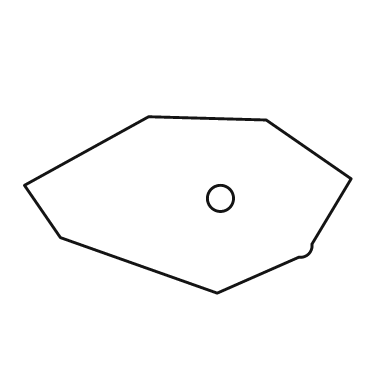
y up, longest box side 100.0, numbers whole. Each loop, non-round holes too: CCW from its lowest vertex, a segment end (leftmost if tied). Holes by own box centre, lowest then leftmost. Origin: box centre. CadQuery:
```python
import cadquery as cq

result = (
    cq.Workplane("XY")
    .moveTo(9.0, -27.0)
    .lineTo(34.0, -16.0)
    .threePointArc((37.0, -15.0), (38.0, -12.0))
    .lineTo(50.0, 8.0)
    .lineTo(24.0, 26.0)
    .lineTo(-12.0, 27.0)
    .lineTo(-50.0, 6.0)
    .lineTo(-39.0, -10.0)
    .close()
    .moveTo(10.0, 2.0)
    .circle(4.0)
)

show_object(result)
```